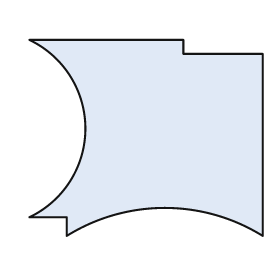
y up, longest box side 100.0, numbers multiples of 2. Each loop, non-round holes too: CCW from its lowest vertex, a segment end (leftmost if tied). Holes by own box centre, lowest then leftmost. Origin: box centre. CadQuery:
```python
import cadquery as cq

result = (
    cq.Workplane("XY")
    .moveTo(-34.0, -42.0)
    .threePointArc((8.0, -30.0), (50.0, -42.0))
    .lineTo(50.0, 36.0)
    .lineTo(16.0, 36.0)
    .lineTo(16.0, 42.0)
    .lineTo(-50.0, 42.0)
    .threePointArc((-26.0, 4.0), (-50.0, -34.0))
    .lineTo(-34.0, -34.0)
    .close()
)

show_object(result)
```